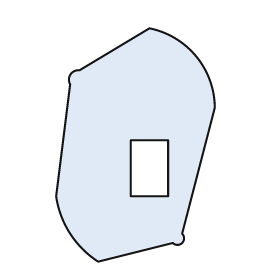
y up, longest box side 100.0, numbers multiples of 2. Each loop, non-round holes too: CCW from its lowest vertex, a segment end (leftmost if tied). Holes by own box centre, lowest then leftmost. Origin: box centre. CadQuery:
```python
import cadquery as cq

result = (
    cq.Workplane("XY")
    .moveTo(-16.0, -50.0)
    .lineTo(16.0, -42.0)
    .threePointArc((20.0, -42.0), (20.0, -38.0))
    .lineTo(34.0, 16.0)
    .threePointArc((26.0, 38.0), (6.0, 50.0))
    .lineTo(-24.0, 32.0)
    .threePointArc((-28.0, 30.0), (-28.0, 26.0))
    .lineTo(-34.0, -22.0)
    .threePointArc((-28.0, -38.0), (-16.0, -50.0))
    .close()
    .moveTo(-2.0, -22.0)
    .lineTo(14.0, -22.0)
    .lineTo(14.0, 2.0)
    .lineTo(-2.0, 2.0)
    .close()
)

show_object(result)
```